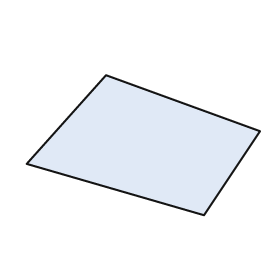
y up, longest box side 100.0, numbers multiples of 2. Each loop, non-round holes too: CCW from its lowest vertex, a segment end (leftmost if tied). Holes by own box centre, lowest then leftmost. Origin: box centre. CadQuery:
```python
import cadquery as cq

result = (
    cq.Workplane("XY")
    .moveTo(26.0, -30.0)
    .lineTo(50.0, 6.0)
    .lineTo(-16.0, 30.0)
    .lineTo(-50.0, -8.0)
    .close()
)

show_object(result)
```